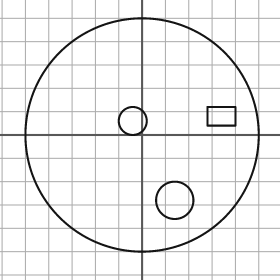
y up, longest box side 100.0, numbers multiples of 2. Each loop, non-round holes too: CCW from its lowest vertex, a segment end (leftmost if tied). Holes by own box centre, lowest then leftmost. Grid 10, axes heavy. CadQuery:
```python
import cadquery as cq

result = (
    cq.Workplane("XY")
    .moveTo(0.0, 0.0)
    .circle(50.0)
    .moveTo(14.0, -28.0)
    .circle(8.0)
    .moveTo(-4.0, 6.0)
    .circle(6.0)
    .moveTo(28.0, 4.0)
    .lineTo(40.0, 4.0)
    .lineTo(40.0, 12.0)
    .lineTo(28.0, 12.0)
    .close()
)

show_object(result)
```